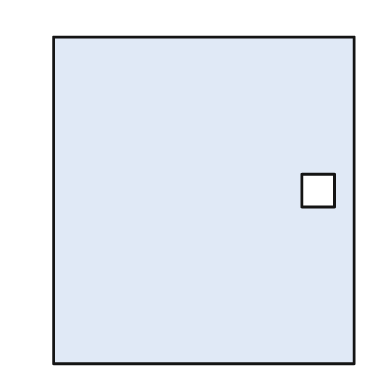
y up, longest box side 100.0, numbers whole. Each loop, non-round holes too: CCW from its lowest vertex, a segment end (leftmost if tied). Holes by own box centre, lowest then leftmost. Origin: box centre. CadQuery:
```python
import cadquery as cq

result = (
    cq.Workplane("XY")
    .moveTo(-46.0, -50.0)
    .lineTo(46.0, -50.0)
    .lineTo(46.0, 50.0)
    .lineTo(-46.0, 50.0)
    .close()
    .moveTo(30.0, -2.0)
    .lineTo(40.0, -2.0)
    .lineTo(40.0, 8.0)
    .lineTo(30.0, 8.0)
    .close()
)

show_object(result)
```